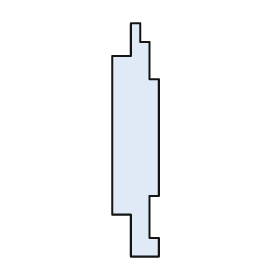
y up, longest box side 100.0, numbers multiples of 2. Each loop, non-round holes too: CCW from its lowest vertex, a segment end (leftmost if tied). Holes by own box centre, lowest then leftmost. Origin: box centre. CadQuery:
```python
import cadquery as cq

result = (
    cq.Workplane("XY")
    .moveTo(-2.0, -50.0)
    .lineTo(10.0, -50.0)
    .lineTo(10.0, -42.0)
    .lineTo(6.0, -42.0)
    .lineTo(6.0, -24.0)
    .lineTo(10.0, -24.0)
    .lineTo(10.0, 26.0)
    .lineTo(6.0, 26.0)
    .lineTo(6.0, 42.0)
    .lineTo(2.0, 42.0)
    .lineTo(2.0, 50.0)
    .lineTo(-2.0, 50.0)
    .lineTo(-2.0, 36.0)
    .lineTo(-10.0, 36.0)
    .lineTo(-10.0, -32.0)
    .lineTo(-2.0, -32.0)
    .close()
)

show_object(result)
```